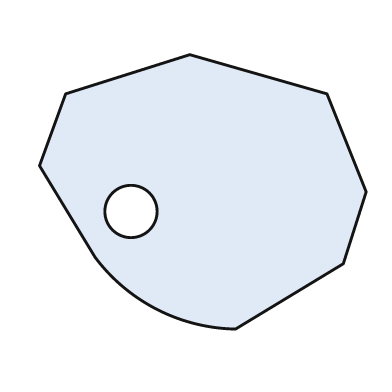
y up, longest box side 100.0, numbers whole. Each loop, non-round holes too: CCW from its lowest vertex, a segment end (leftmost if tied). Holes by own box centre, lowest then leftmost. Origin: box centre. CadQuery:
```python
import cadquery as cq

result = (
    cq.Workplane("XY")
    .moveTo(10.0, -42.0)
    .lineTo(43.0, -22.0)
    .lineTo(50.0, 0.0)
    .lineTo(38.0, 30.0)
    .lineTo(-4.0, 42.0)
    .lineTo(-42.0, 30.0)
    .lineTo(-50.0, 8.0)
    .lineTo(-33.0, -20.0)
    .threePointArc((-14.0, -36.0), (10.0, -42.0))
    .close()
    .moveTo(-22.0, -6.0)
    .circle(8.0)
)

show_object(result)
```